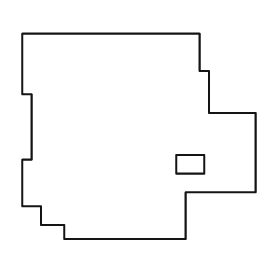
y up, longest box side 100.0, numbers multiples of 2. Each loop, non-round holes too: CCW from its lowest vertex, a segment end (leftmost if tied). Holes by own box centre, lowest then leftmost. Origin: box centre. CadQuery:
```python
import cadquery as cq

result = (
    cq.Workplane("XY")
    .moveTo(-32.0, -44.0)
    .lineTo(20.0, -44.0)
    .lineTo(20.0, -24.0)
    .lineTo(50.0, -24.0)
    .lineTo(50.0, 10.0)
    .lineTo(30.0, 10.0)
    .lineTo(30.0, 28.0)
    .lineTo(26.0, 28.0)
    .lineTo(26.0, 44.0)
    .lineTo(-50.0, 44.0)
    .lineTo(-50.0, 18.0)
    .lineTo(-46.0, 18.0)
    .lineTo(-46.0, -10.0)
    .lineTo(-50.0, -10.0)
    .lineTo(-50.0, -30.0)
    .lineTo(-42.0, -30.0)
    .lineTo(-42.0, -38.0)
    .lineTo(-32.0, -38.0)
    .close()
    .moveTo(16.0, -16.0)
    .lineTo(28.0, -16.0)
    .lineTo(28.0, -8.0)
    .lineTo(16.0, -8.0)
    .close()
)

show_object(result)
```